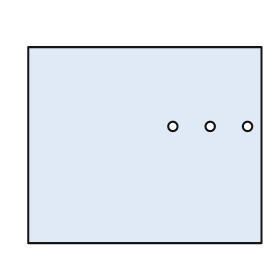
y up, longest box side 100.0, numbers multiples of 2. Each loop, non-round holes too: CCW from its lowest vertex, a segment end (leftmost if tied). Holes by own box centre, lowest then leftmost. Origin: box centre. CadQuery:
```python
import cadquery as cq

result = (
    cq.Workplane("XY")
    .moveTo(-50.0, -42.0)
    .lineTo(50.0, -42.0)
    .lineTo(50.0, 42.0)
    .lineTo(-50.0, 42.0)
    .close()
    .moveTo(12.0, 8.0)
    .circle(2.0)
    .moveTo(28.0, 8.0)
    .circle(2.0)
    .moveTo(44.0, 8.0)
    .circle(2.0)
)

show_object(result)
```